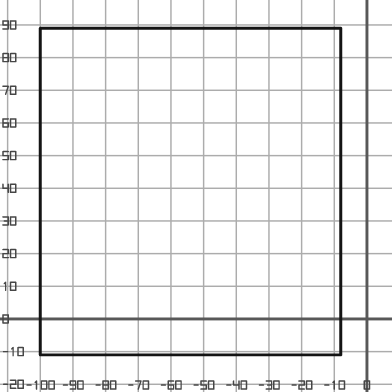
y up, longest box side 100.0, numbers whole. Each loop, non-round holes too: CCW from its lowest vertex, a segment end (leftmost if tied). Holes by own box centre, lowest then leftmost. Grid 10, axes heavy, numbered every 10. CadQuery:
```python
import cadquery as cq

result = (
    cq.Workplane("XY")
    .moveTo(-100.0, -11.0)
    .lineTo(-8.0, -11.0)
    .lineTo(-8.0, 89.0)
    .lineTo(-100.0, 89.0)
    .close()
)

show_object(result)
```